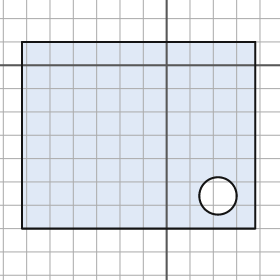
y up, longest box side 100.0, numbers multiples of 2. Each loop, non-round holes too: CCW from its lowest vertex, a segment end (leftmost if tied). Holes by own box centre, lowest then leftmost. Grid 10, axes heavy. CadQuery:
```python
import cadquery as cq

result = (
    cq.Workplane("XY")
    .moveTo(-62.0, -70.0)
    .lineTo(38.0, -70.0)
    .lineTo(38.0, 10.0)
    .lineTo(-62.0, 10.0)
    .close()
    .moveTo(22.0, -56.0)
    .circle(8.0)
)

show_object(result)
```